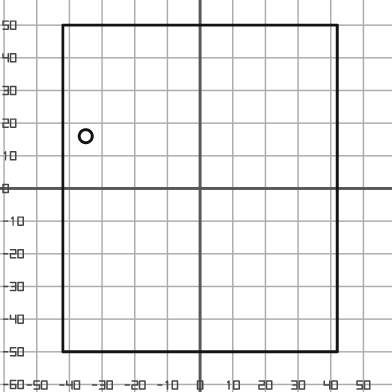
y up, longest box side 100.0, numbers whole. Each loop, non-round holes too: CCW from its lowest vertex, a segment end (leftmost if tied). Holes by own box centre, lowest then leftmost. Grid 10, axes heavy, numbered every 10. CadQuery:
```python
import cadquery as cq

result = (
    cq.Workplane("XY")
    .moveTo(-42.0, -50.0)
    .lineTo(42.0, -50.0)
    .lineTo(42.0, 50.0)
    .lineTo(-42.0, 50.0)
    .close()
    .moveTo(-35.0, 16.0)
    .circle(2.0)
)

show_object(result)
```